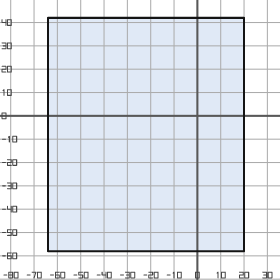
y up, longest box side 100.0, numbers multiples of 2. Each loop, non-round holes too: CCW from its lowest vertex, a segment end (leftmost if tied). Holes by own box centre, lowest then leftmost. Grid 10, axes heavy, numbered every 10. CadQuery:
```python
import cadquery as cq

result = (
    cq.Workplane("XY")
    .moveTo(-64.0, -58.0)
    .lineTo(20.0, -58.0)
    .lineTo(20.0, 42.0)
    .lineTo(-64.0, 42.0)
    .close()
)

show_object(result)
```